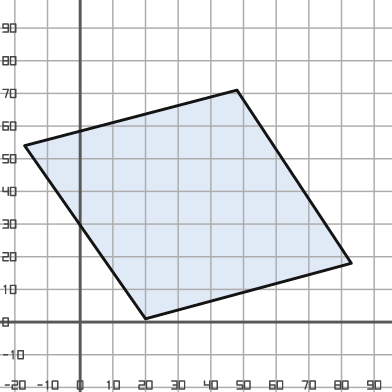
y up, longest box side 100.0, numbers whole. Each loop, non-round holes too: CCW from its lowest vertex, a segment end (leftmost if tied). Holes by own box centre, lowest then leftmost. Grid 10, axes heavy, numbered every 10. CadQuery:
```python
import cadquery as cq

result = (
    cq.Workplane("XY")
    .moveTo(20.0, 1.0)
    .lineTo(83.0, 18.0)
    .lineTo(48.0, 71.0)
    .lineTo(-17.0, 54.0)
    .close()
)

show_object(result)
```